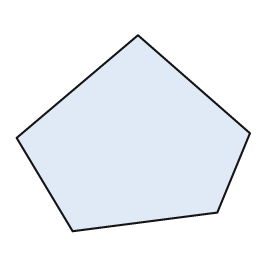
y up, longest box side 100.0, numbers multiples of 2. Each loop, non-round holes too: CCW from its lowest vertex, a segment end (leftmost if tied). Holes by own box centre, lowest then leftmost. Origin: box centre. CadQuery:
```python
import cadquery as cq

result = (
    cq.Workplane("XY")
    .moveTo(-26.0, -42.0)
    .lineTo(36.0, -34.0)
    .lineTo(50.0, 0.0)
    .lineTo(2.0, 42.0)
    .lineTo(-50.0, -2.0)
    .close()
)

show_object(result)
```